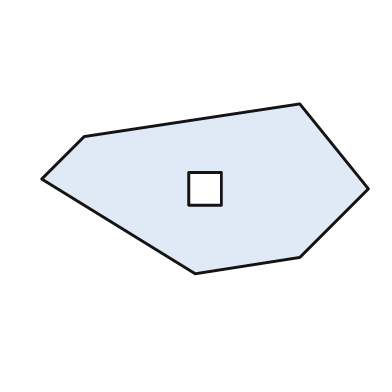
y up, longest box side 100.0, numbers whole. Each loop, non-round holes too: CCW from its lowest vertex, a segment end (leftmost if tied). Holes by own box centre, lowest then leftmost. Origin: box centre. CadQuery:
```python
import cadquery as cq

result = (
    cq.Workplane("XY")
    .moveTo(-3.0, -26.0)
    .lineTo(29.0, -21.0)
    .lineTo(50.0, 0.0)
    .lineTo(29.0, 26.0)
    .lineTo(-37.0, 16.0)
    .lineTo(-50.0, 3.0)
    .close()
    .moveTo(-5.0, -5.0)
    .lineTo(5.0, -5.0)
    .lineTo(5.0, 5.0)
    .lineTo(-5.0, 5.0)
    .close()
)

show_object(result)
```